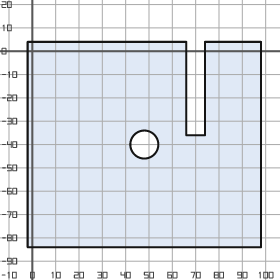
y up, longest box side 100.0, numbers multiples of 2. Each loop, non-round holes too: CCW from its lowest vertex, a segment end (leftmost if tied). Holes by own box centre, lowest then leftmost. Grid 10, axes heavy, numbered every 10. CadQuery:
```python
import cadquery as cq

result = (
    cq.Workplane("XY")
    .moveTo(-2.0, -84.0)
    .lineTo(98.0, -84.0)
    .lineTo(98.0, 4.0)
    .lineTo(74.0, 4.0)
    .lineTo(74.0, -36.0)
    .lineTo(66.0, -36.0)
    .lineTo(66.0, 4.0)
    .lineTo(-2.0, 4.0)
    .close()
    .moveTo(48.0, -40.0)
    .circle(6.0)
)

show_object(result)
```